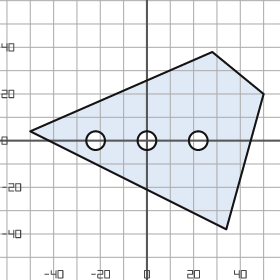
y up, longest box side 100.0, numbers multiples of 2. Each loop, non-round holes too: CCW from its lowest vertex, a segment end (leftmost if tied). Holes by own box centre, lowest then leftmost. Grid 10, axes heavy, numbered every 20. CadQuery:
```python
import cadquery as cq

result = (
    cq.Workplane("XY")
    .moveTo(34.0, -38.0)
    .lineTo(50.0, 20.0)
    .lineTo(28.0, 38.0)
    .lineTo(-50.0, 4.0)
    .close()
    .moveTo(-22.0, 0.0)
    .circle(4.0)
    .moveTo(0.0, 0.0)
    .circle(4.0)
    .moveTo(22.0, 0.0)
    .circle(4.0)
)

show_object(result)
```